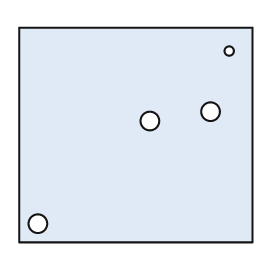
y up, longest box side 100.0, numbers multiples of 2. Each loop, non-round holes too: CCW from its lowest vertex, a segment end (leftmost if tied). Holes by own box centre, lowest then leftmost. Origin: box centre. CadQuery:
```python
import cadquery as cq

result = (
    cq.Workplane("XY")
    .moveTo(-50.0, -46.0)
    .lineTo(50.0, -46.0)
    .lineTo(50.0, 46.0)
    .lineTo(-50.0, 46.0)
    .close()
    .moveTo(-42.0, -38.0)
    .circle(4.0)
    .moveTo(6.0, 6.0)
    .circle(4.0)
    .moveTo(32.0, 10.0)
    .circle(4.0)
    .moveTo(40.0, 36.0)
    .circle(2.0)
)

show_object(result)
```